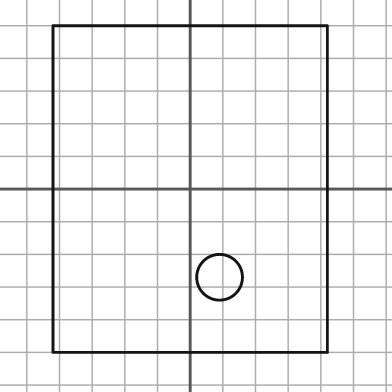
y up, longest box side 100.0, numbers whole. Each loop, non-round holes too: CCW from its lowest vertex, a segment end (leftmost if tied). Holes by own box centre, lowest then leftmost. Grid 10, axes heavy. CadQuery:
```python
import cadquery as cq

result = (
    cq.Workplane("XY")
    .moveTo(-42.0, -50.0)
    .lineTo(42.0, -50.0)
    .lineTo(42.0, 50.0)
    .lineTo(-42.0, 50.0)
    .close()
    .moveTo(9.0, -27.0)
    .circle(7.0)
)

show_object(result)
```